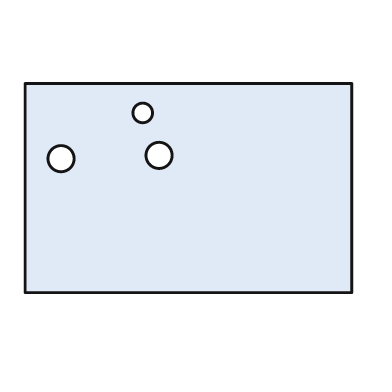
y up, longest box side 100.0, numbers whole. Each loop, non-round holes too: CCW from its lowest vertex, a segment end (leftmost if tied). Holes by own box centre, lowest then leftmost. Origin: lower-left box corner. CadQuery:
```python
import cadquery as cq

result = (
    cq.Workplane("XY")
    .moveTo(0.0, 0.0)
    .lineTo(100.0, 0.0)
    .lineTo(100.0, 64.0)
    .lineTo(0.0, 64.0)
    .close()
    .moveTo(11.0, 41.0)
    .circle(4.0)
    .moveTo(41.0, 42.0)
    .circle(4.0)
    .moveTo(36.0, 55.0)
    .circle(3.0)
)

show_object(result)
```